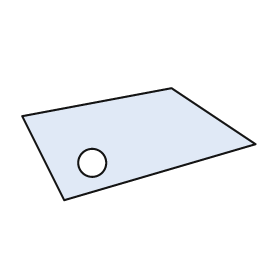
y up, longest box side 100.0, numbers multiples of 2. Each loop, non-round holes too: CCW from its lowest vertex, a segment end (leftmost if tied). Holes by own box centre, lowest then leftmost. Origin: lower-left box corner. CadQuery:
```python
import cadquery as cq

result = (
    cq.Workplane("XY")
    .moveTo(18.0, 0.0)
    .lineTo(100.0, 24.0)
    .lineTo(64.0, 48.0)
    .lineTo(0.0, 36.0)
    .close()
    .moveTo(30.0, 16.0)
    .circle(6.0)
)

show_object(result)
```